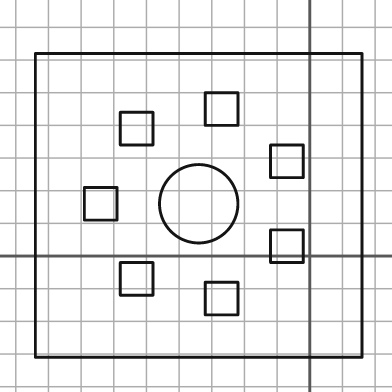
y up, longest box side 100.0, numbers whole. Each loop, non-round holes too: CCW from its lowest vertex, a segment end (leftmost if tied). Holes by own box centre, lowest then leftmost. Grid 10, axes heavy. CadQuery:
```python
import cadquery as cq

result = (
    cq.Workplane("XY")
    .moveTo(-84.0, -31.0)
    .lineTo(16.0, -31.0)
    .lineTo(16.0, 62.0)
    .lineTo(-84.0, 62.0)
    .close()
    .moveTo(-32.0, -18.0)
    .lineTo(-22.0, -18.0)
    .lineTo(-22.0, -8.0)
    .lineTo(-32.0, -8.0)
    .close()
    .moveTo(-58.0, -12.0)
    .lineTo(-48.0, -12.0)
    .lineTo(-48.0, -2.0)
    .lineTo(-58.0, -2.0)
    .close()
    .moveTo(-12.0, -2.0)
    .lineTo(-2.0, -2.0)
    .lineTo(-2.0, 8.0)
    .lineTo(-12.0, 8.0)
    .close()
    .moveTo(-69.0, 11.0)
    .lineTo(-59.0, 11.0)
    .lineTo(-59.0, 21.0)
    .lineTo(-69.0, 21.0)
    .close()
    .moveTo(-34.0, 16.0)
    .circle(12.0)
    .moveTo(-12.0, 24.0)
    .lineTo(-2.0, 24.0)
    .lineTo(-2.0, 34.0)
    .lineTo(-12.0, 34.0)
    .close()
    .moveTo(-58.0, 34.0)
    .lineTo(-48.0, 34.0)
    .lineTo(-48.0, 44.0)
    .lineTo(-58.0, 44.0)
    .close()
    .moveTo(-32.0, 40.0)
    .lineTo(-22.0, 40.0)
    .lineTo(-22.0, 50.0)
    .lineTo(-32.0, 50.0)
    .close()
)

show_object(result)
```